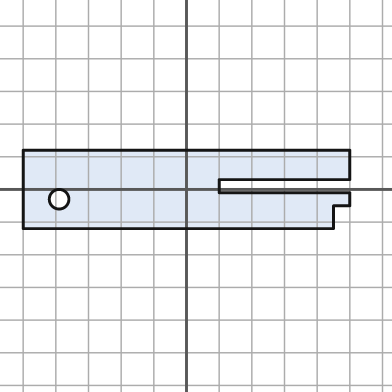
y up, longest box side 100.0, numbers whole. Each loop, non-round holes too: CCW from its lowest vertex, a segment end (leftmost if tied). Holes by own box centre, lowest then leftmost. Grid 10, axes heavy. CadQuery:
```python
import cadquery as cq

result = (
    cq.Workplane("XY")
    .moveTo(-50.0, -12.0)
    .lineTo(45.0, -12.0)
    .lineTo(45.0, -5.0)
    .lineTo(50.0, -5.0)
    .lineTo(50.0, -1.0)
    .lineTo(10.0, -1.0)
    .lineTo(10.0, 3.0)
    .lineTo(50.0, 3.0)
    .lineTo(50.0, 12.0)
    .lineTo(-50.0, 12.0)
    .close()
    .moveTo(-39.0, -3.0)
    .circle(3.0)
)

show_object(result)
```